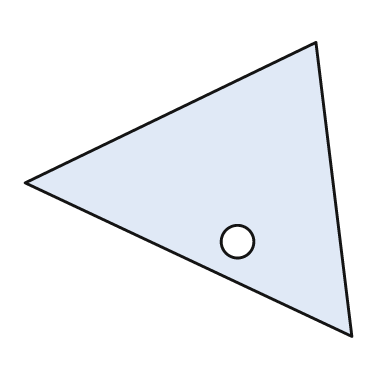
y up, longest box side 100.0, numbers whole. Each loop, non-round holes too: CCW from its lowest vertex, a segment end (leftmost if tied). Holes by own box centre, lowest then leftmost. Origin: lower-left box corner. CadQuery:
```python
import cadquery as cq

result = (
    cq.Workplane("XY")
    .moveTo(100.0, 0.0)
    .lineTo(89.0, 90.0)
    .lineTo(0.0, 47.0)
    .close()
    .moveTo(65.0, 29.0)
    .circle(5.0)
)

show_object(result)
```